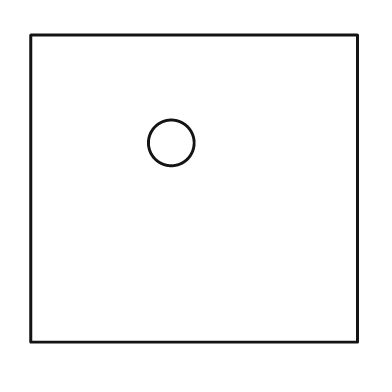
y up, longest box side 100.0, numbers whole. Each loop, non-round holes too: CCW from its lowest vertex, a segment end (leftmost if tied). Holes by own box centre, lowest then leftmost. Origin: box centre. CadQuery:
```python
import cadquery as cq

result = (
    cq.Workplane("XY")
    .moveTo(-50.0, -47.0)
    .lineTo(50.0, -47.0)
    .lineTo(50.0, 47.0)
    .lineTo(-50.0, 47.0)
    .close()
    .moveTo(-7.0, 14.0)
    .circle(7.0)
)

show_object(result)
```